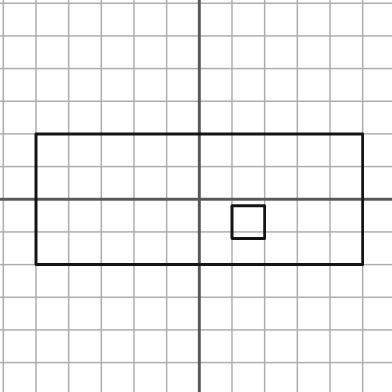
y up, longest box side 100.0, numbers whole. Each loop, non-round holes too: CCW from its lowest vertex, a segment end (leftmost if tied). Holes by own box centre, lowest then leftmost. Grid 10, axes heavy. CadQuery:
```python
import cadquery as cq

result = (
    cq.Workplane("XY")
    .moveTo(-50.0, -20.0)
    .lineTo(50.0, -20.0)
    .lineTo(50.0, 20.0)
    .lineTo(-50.0, 20.0)
    .close()
    .moveTo(10.0, -12.0)
    .lineTo(20.0, -12.0)
    .lineTo(20.0, -2.0)
    .lineTo(10.0, -2.0)
    .close()
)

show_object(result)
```